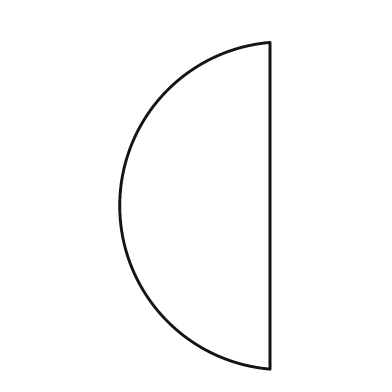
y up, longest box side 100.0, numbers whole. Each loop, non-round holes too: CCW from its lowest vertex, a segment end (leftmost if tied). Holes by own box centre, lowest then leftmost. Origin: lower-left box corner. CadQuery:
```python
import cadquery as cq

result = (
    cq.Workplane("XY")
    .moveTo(46.0, 0.0)
    .lineTo(46.0, 100.0)
    .threePointArc((0.0, 50.0), (46.0, 0.0))
    .close()
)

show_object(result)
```